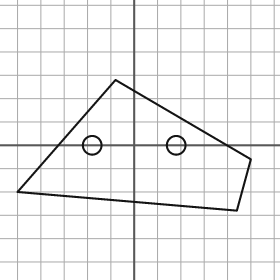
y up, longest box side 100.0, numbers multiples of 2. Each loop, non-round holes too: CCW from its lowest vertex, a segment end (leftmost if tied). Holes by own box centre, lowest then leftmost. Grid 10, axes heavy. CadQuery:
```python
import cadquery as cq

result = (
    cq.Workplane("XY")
    .moveTo(44.0, -28.0)
    .lineTo(50.0, -6.0)
    .lineTo(-8.0, 28.0)
    .lineTo(-50.0, -20.0)
    .close()
    .moveTo(-18.0, 0.0)
    .circle(4.0)
    .moveTo(18.0, 0.0)
    .circle(4.0)
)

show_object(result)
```